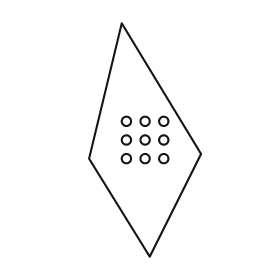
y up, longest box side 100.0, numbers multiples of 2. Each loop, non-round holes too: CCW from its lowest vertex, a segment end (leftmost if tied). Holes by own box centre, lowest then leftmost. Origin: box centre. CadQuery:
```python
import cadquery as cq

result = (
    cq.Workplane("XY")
    .moveTo(2.0, -50.0)
    .lineTo(24.0, -6.0)
    .lineTo(-10.0, 50.0)
    .lineTo(-24.0, -8.0)
    .close()
    .moveTo(-8.0, -8.0)
    .circle(2.0)
    .moveTo(0.0, -8.0)
    .circle(2.0)
    .moveTo(8.0, -8.0)
    .circle(2.0)
    .moveTo(-8.0, 0.0)
    .circle(2.0)
    .moveTo(0.0, 0.0)
    .circle(2.0)
    .moveTo(8.0, 0.0)
    .circle(2.0)
    .moveTo(-8.0, 8.0)
    .circle(2.0)
    .moveTo(0.0, 8.0)
    .circle(2.0)
    .moveTo(8.0, 8.0)
    .circle(2.0)
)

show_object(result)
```